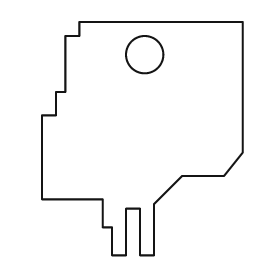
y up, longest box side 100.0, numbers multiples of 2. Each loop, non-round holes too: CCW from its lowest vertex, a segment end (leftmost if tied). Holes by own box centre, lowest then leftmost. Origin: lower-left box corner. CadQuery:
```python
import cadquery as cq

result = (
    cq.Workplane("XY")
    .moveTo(30.0, 0.0)
    .lineTo(36.0, 0.0)
    .lineTo(36.0, 20.0)
    .lineTo(42.0, 20.0)
    .lineTo(42.0, 0.0)
    .lineTo(48.0, 0.0)
    .lineTo(48.0, 22.0)
    .lineTo(60.0, 34.0)
    .lineTo(78.0, 34.0)
    .lineTo(86.0, 44.0)
    .lineTo(86.0, 100.0)
    .lineTo(16.0, 100.0)
    .lineTo(16.0, 94.0)
    .lineTo(10.0, 94.0)
    .lineTo(10.0, 70.0)
    .lineTo(6.0, 70.0)
    .lineTo(6.0, 60.0)
    .lineTo(0.0, 60.0)
    .lineTo(0.0, 24.0)
    .lineTo(26.0, 24.0)
    .lineTo(26.0, 12.0)
    .lineTo(30.0, 12.0)
    .close()
    .moveTo(44.0, 86.0)
    .circle(8.0)
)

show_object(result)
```